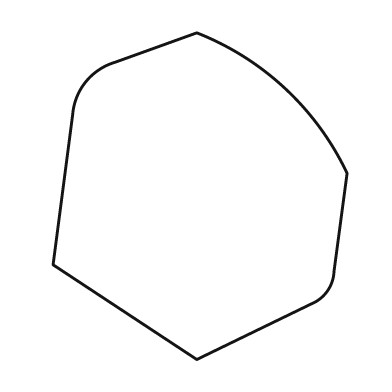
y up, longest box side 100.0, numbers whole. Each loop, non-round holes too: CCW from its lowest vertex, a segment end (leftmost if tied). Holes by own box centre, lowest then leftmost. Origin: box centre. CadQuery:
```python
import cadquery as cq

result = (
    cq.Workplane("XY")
    .moveTo(-1.0, -50.0)
    .lineTo(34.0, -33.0)
    .threePointArc((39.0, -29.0), (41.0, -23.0))
    .lineTo(45.0, 7.0)
    .threePointArc((26.0, 33.0), (-1.0, 50.0))
    .lineTo(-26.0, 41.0)
    .threePointArc((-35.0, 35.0), (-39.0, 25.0))
    .lineTo(-45.0, -21.0)
    .close()
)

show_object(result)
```